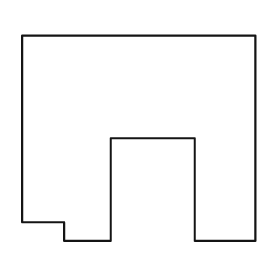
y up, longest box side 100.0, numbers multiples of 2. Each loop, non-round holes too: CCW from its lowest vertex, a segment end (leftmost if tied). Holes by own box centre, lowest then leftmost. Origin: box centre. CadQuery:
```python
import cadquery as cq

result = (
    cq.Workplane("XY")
    .moveTo(-32.0, -44.0)
    .lineTo(-12.0, -44.0)
    .lineTo(-12.0, 0.0)
    .lineTo(24.0, 0.0)
    .lineTo(24.0, -44.0)
    .lineTo(50.0, -44.0)
    .lineTo(50.0, 44.0)
    .lineTo(-50.0, 44.0)
    .lineTo(-50.0, -36.0)
    .lineTo(-32.0, -36.0)
    .close()
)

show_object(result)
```